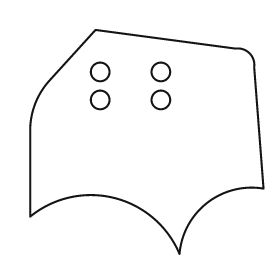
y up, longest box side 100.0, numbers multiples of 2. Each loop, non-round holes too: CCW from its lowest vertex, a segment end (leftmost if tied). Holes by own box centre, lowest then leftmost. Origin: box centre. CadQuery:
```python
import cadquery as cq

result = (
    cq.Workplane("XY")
    .moveTo(14.0, -48.0)
    .threePointArc((26.0, -26.0), (50.0, -20.0))
    .lineTo(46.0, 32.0)
    .threePointArc((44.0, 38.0), (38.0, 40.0))
    .lineTo(-22.0, 48.0)
    .lineTo(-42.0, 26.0)
    .threePointArc((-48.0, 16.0), (-50.0, 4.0))
    .lineTo(-50.0, -32.0)
    .threePointArc((-14.0, -24.0), (14.0, -48.0))
    .close()
    .moveTo(-20.0, 18.0)
    .circle(4.0)
    .moveTo(6.0, 18.0)
    .circle(4.0)
    .moveTo(-20.0, 30.0)
    .circle(4.0)
    .moveTo(6.0, 30.0)
    .circle(4.0)
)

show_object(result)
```